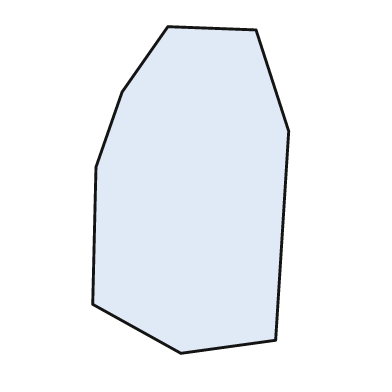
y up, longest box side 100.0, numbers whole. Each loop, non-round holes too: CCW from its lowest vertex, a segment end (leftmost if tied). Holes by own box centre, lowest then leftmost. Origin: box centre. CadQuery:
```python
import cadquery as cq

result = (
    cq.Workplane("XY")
    .moveTo(-3.0, -50.0)
    .lineTo(26.0, -46.0)
    .lineTo(30.0, 18.0)
    .lineTo(20.0, 49.0)
    .lineTo(-7.0, 50.0)
    .lineTo(-21.0, 30.0)
    .lineTo(-29.0, 7.0)
    .lineTo(-30.0, -35.0)
    .close()
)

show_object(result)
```